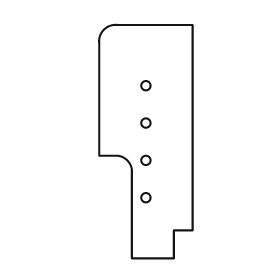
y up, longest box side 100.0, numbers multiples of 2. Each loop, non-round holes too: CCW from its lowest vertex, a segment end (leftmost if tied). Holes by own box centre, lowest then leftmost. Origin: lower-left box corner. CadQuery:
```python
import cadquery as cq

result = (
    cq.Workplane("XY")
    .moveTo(14.0, 0.0)
    .lineTo(32.0, 0.0)
    .lineTo(32.0, 12.0)
    .lineTo(40.0, 12.0)
    .lineTo(40.0, 100.0)
    .lineTo(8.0, 100.0)
    .threePointArc((2.0, 98.0), (0.0, 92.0))
    .lineTo(0.0, 44.0)
    .lineTo(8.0, 44.0)
    .threePointArc((12.0, 42.0), (14.0, 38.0))
    .close()
    .moveTo(20.0, 26.0)
    .circle(2.0)
    .moveTo(20.0, 42.0)
    .circle(2.0)
    .moveTo(20.0, 58.0)
    .circle(2.0)
    .moveTo(20.0, 74.0)
    .circle(2.0)
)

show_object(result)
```